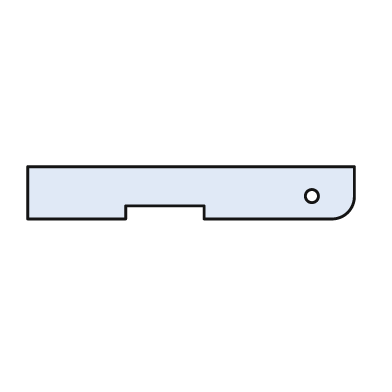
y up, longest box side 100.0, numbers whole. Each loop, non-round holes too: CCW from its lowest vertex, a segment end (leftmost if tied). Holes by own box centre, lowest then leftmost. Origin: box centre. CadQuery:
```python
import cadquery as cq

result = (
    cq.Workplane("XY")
    .moveTo(-50.0, -8.0)
    .lineTo(-20.0, -8.0)
    .lineTo(-20.0, -4.0)
    .lineTo(4.0, -4.0)
    .lineTo(4.0, -8.0)
    .lineTo(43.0, -8.0)
    .threePointArc((48.0, -6.0), (50.0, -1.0))
    .lineTo(50.0, 8.0)
    .lineTo(-50.0, 8.0)
    .close()
    .moveTo(37.0, -1.0)
    .circle(2.0)
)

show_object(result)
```